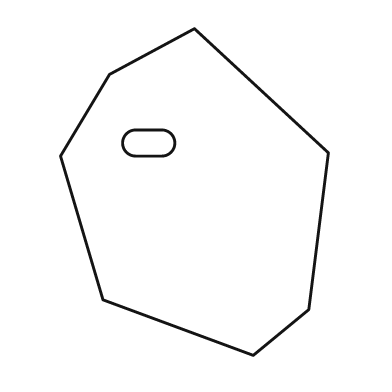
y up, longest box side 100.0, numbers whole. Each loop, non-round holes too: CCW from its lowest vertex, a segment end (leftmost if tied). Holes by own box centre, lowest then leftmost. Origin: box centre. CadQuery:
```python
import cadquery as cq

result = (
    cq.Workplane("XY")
    .moveTo(18.0, -50.0)
    .lineTo(35.0, -36.0)
    .lineTo(41.0, 12.0)
    .lineTo(0.0, 50.0)
    .lineTo(-26.0, 36.0)
    .lineTo(-41.0, 11.0)
    .lineTo(-28.0, -33.0)
    .close()
    .moveTo(-18.0, 11.0)
    .lineTo(-10.0, 11.0)
    .threePointArc((-6.0, 15.0), (-10.0, 19.0))
    .lineTo(-18.0, 19.0)
    .threePointArc((-22.0, 15.0), (-18.0, 11.0))
    .close()
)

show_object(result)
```